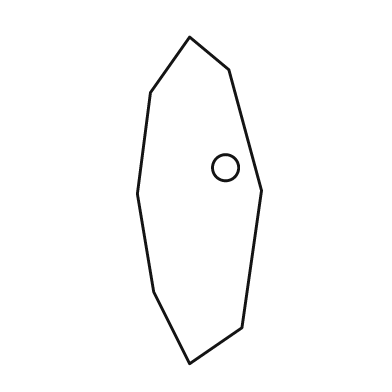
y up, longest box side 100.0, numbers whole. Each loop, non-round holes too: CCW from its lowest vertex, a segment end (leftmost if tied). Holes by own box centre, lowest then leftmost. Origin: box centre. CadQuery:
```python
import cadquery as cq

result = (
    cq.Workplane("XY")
    .moveTo(-3.0, -50.0)
    .lineTo(13.0, -39.0)
    .lineTo(19.0, 3.0)
    .lineTo(9.0, 40.0)
    .lineTo(-3.0, 50.0)
    .lineTo(-15.0, 33.0)
    .lineTo(-19.0, 2.0)
    .lineTo(-14.0, -28.0)
    .close()
    .moveTo(8.0, 10.0)
    .circle(4.0)
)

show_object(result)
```